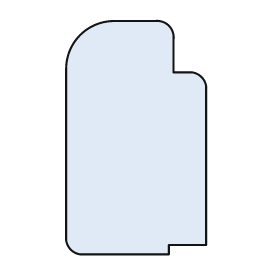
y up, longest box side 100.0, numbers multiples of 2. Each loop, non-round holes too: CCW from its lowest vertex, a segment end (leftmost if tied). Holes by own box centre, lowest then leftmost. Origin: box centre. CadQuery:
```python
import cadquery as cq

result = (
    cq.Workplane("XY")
    .moveTo(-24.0, -50.0)
    .lineTo(14.0, -50.0)
    .lineTo(14.0, -46.0)
    .lineTo(30.0, -46.0)
    .lineTo(30.0, 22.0)
    .threePointArc((28.0, 26.0), (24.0, 28.0))
    .lineTo(16.0, 28.0)
    .lineTo(16.0, 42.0)
    .threePointArc((14.0, 48.0), (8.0, 50.0))
    .lineTo(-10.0, 50.0)
    .threePointArc((-24.0, 44.0), (-30.0, 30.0))
    .lineTo(-30.0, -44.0)
    .threePointArc((-28.0, -48.0), (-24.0, -50.0))
    .close()
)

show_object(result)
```